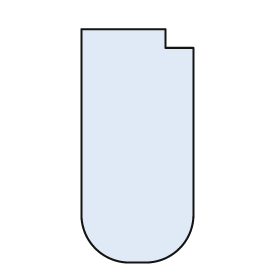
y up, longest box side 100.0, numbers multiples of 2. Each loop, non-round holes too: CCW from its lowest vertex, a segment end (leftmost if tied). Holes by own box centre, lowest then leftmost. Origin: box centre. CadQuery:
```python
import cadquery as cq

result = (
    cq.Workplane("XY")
    .moveTo(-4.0, -50.0)
    .lineTo(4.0, -50.0)
    .threePointArc((18.0, -44.0), (24.0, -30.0))
    .lineTo(24.0, 42.0)
    .lineTo(12.0, 42.0)
    .lineTo(12.0, 50.0)
    .lineTo(-24.0, 50.0)
    .lineTo(-24.0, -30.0)
    .threePointArc((-18.0, -44.0), (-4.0, -50.0))
    .close()
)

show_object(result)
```